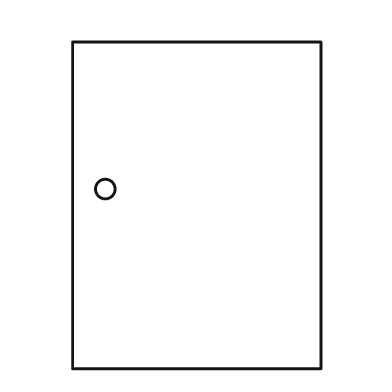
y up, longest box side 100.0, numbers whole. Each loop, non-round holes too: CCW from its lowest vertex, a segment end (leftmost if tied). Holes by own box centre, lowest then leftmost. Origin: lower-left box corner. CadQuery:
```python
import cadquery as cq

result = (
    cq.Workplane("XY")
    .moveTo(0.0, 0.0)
    .lineTo(76.0, 0.0)
    .lineTo(76.0, 100.0)
    .lineTo(0.0, 100.0)
    .close()
    .moveTo(10.0, 55.0)
    .circle(3.0)
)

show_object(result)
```